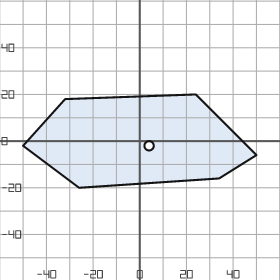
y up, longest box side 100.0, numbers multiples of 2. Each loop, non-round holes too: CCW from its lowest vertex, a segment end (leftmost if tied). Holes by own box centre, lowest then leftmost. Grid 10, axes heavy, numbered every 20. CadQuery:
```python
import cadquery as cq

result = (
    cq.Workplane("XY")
    .moveTo(-26.0, -20.0)
    .lineTo(34.0, -16.0)
    .lineTo(50.0, -6.0)
    .lineTo(24.0, 20.0)
    .lineTo(-32.0, 18.0)
    .lineTo(-50.0, -2.0)
    .close()
    .moveTo(4.0, -2.0)
    .circle(2.0)
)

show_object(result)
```